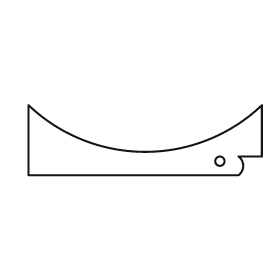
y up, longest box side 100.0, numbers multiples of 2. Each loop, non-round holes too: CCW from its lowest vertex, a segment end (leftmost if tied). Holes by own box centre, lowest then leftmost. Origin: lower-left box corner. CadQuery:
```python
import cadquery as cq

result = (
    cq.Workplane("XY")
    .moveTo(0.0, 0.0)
    .lineTo(90.0, 0.0)
    .threePointArc((92.0, 4.0), (90.0, 8.0))
    .lineTo(100.0, 8.0)
    .lineTo(100.0, 30.0)
    .threePointArc((50.0, 10.0), (0.0, 30.0))
    .close()
    .moveTo(82.0, 6.0)
    .circle(2.0)
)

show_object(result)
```